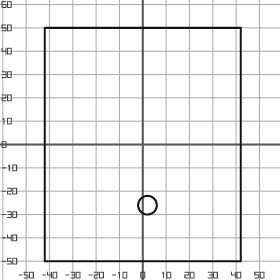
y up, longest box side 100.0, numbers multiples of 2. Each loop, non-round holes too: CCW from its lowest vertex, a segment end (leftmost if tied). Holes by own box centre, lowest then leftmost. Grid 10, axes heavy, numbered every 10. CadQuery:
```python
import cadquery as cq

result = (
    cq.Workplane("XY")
    .moveTo(-42.0, -50.0)
    .lineTo(42.0, -50.0)
    .lineTo(42.0, 50.0)
    .lineTo(-42.0, 50.0)
    .close()
    .moveTo(2.0, -26.0)
    .circle(4.0)
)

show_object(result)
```